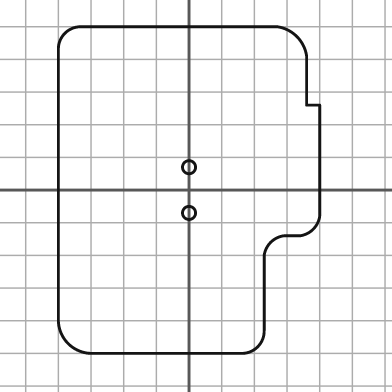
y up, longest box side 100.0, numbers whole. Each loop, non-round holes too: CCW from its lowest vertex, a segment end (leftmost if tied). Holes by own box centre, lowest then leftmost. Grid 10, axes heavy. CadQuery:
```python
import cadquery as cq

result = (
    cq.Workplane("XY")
    .moveTo(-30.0, -50.0)
    .lineTo(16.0, -50.0)
    .threePointArc((21.0, -48.0), (23.0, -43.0))
    .lineTo(23.0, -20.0)
    .threePointArc((25.0, -16.0), (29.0, -14.0))
    .lineTo(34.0, -14.0)
    .threePointArc((38.0, -12.0), (40.0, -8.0))
    .lineTo(40.0, 26.0)
    .lineTo(36.0, 26.0)
    .lineTo(36.0, 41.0)
    .threePointArc((33.0, 47.0), (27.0, 50.0))
    .lineTo(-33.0, 50.0)
    .threePointArc((-38.0, 48.0), (-40.0, 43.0))
    .lineTo(-40.0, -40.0)
    .threePointArc((-37.0, -47.0), (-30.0, -50.0))
    .close()
    .moveTo(0.0, -7.0)
    .circle(2.0)
    .moveTo(0.0, 7.0)
    .circle(2.0)
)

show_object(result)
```